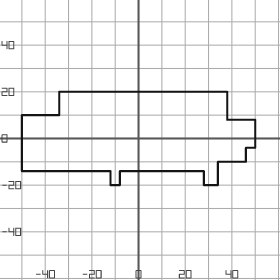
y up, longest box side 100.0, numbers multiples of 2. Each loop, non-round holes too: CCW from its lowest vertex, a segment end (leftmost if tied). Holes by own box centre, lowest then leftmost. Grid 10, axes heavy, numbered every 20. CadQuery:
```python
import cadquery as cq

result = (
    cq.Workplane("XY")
    .moveTo(-12.0, -20.0)
    .lineTo(-8.0, -20.0)
    .lineTo(-8.0, -14.0)
    .lineTo(28.0, -14.0)
    .lineTo(28.0, -20.0)
    .lineTo(34.0, -20.0)
    .lineTo(34.0, -10.0)
    .lineTo(46.0, -10.0)
    .lineTo(46.0, -4.0)
    .lineTo(50.0, -4.0)
    .lineTo(50.0, 8.0)
    .lineTo(38.0, 8.0)
    .lineTo(38.0, 20.0)
    .lineTo(-34.0, 20.0)
    .lineTo(-34.0, 10.0)
    .lineTo(-50.0, 10.0)
    .lineTo(-50.0, -14.0)
    .lineTo(-12.0, -14.0)
    .close()
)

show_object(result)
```